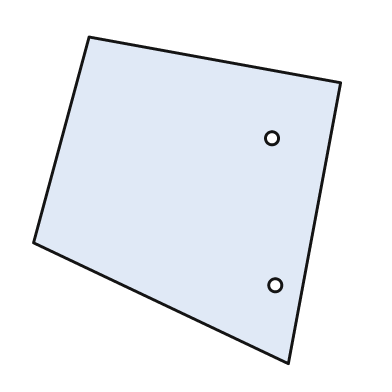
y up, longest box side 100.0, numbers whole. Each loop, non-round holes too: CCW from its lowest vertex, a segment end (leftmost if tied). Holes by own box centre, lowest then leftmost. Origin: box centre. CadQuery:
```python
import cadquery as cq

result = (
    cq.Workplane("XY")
    .moveTo(31.0, -50.0)
    .lineTo(47.0, 36.0)
    .lineTo(-30.0, 50.0)
    .lineTo(-47.0, -13.0)
    .close()
    .moveTo(27.0, -26.0)
    .circle(2.0)
    .moveTo(26.0, 19.0)
    .circle(2.0)
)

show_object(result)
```